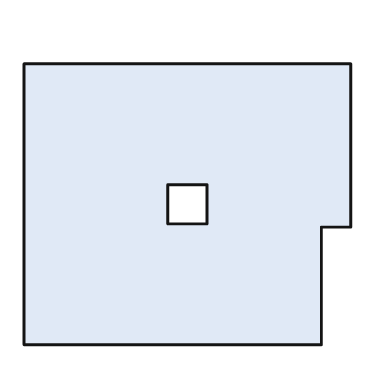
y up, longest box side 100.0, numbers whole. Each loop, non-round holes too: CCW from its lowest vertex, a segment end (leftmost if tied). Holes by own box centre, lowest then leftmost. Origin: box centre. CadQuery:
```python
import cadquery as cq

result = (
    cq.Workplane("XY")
    .moveTo(-50.0, -43.0)
    .lineTo(41.0, -43.0)
    .lineTo(41.0, -7.0)
    .lineTo(50.0, -7.0)
    .lineTo(50.0, 43.0)
    .lineTo(-50.0, 43.0)
    .close()
    .moveTo(-6.0, -6.0)
    .lineTo(6.0, -6.0)
    .lineTo(6.0, 6.0)
    .lineTo(-6.0, 6.0)
    .close()
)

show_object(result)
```